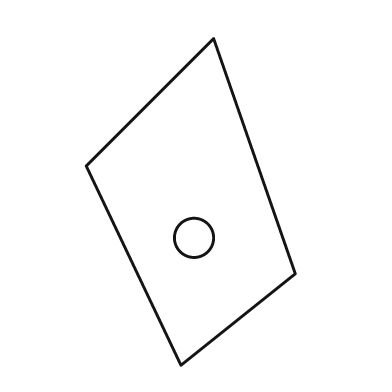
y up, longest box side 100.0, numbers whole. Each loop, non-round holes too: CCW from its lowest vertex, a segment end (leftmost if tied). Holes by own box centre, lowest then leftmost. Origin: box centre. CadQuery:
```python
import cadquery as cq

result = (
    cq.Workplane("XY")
    .moveTo(-3.0, -50.0)
    .lineTo(32.0, -22.0)
    .lineTo(7.0, 50.0)
    .lineTo(-32.0, 11.0)
    .close()
    .moveTo(1.0, -11.0)
    .circle(6.0)
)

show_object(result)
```